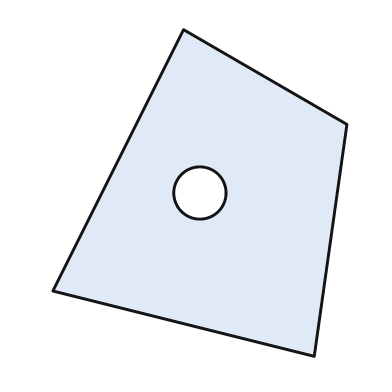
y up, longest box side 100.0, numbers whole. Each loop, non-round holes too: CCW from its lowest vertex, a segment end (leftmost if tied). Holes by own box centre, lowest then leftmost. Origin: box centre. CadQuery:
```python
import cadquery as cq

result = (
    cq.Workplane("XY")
    .moveTo(35.0, -50.0)
    .lineTo(45.0, 21.0)
    .lineTo(-5.0, 50.0)
    .lineTo(-45.0, -30.0)
    .close()
    .moveTo(0.0, 0.0)
    .circle(8.0)
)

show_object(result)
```